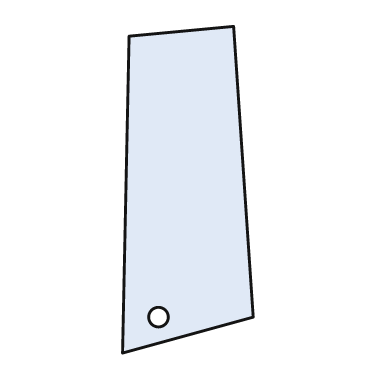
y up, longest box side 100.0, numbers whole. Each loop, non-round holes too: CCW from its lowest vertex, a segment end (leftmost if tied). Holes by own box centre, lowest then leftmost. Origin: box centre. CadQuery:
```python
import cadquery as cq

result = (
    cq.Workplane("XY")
    .moveTo(-20.0, -50.0)
    .lineTo(20.0, -39.0)
    .lineTo(14.0, 50.0)
    .lineTo(-18.0, 47.0)
    .close()
    .moveTo(-9.0, -39.0)
    .circle(3.0)
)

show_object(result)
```